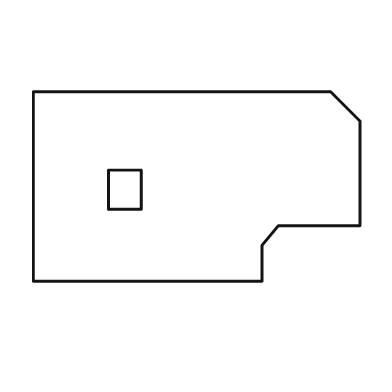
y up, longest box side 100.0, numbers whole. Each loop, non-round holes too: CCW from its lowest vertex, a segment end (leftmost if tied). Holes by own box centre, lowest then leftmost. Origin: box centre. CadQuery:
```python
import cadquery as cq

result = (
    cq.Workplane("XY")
    .moveTo(-50.0, -29.0)
    .lineTo(20.0, -29.0)
    .lineTo(20.0, -18.0)
    .lineTo(25.0, -12.0)
    .lineTo(50.0, -12.0)
    .lineTo(50.0, 20.0)
    .lineTo(41.0, 29.0)
    .lineTo(-50.0, 29.0)
    .close()
    .moveTo(-27.0, -7.0)
    .lineTo(-17.0, -7.0)
    .lineTo(-17.0, 5.0)
    .lineTo(-27.0, 5.0)
    .close()
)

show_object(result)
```